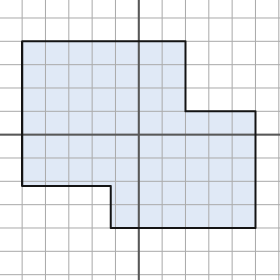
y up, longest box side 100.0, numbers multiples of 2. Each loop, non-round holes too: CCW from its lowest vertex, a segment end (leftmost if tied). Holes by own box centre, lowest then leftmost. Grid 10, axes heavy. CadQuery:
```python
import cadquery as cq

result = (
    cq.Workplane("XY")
    .moveTo(-12.0, -40.0)
    .lineTo(50.0, -40.0)
    .lineTo(50.0, 10.0)
    .lineTo(20.0, 10.0)
    .lineTo(20.0, 40.0)
    .lineTo(-50.0, 40.0)
    .lineTo(-50.0, -22.0)
    .lineTo(-12.0, -22.0)
    .close()
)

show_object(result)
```